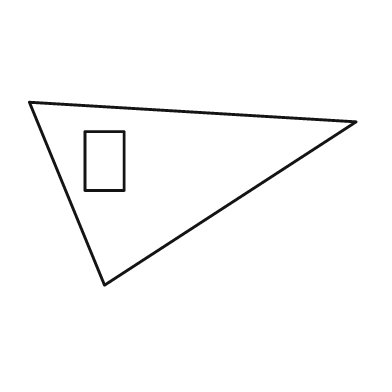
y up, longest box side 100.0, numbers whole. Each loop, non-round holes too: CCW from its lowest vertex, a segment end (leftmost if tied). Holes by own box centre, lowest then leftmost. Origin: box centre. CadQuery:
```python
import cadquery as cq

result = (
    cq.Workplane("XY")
    .moveTo(-27.0, -28.0)
    .lineTo(50.0, 22.0)
    .lineTo(-50.0, 28.0)
    .close()
    .moveTo(-33.0, 1.0)
    .lineTo(-21.0, 1.0)
    .lineTo(-21.0, 19.0)
    .lineTo(-33.0, 19.0)
    .close()
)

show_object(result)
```